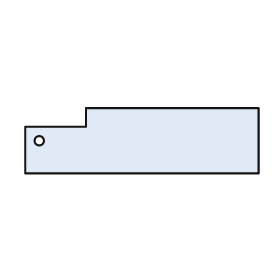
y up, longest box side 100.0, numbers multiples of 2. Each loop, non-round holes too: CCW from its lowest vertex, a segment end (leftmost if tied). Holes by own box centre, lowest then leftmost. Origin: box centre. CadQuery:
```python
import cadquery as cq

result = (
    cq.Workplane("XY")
    .moveTo(-50.0, -14.0)
    .lineTo(50.0, -14.0)
    .lineTo(50.0, 14.0)
    .lineTo(-24.0, 14.0)
    .lineTo(-24.0, 6.0)
    .lineTo(-50.0, 6.0)
    .close()
    .moveTo(-44.0, 0.0)
    .circle(2.0)
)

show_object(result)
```